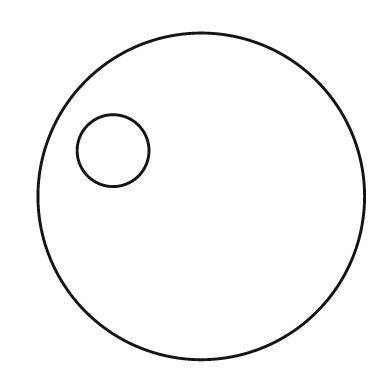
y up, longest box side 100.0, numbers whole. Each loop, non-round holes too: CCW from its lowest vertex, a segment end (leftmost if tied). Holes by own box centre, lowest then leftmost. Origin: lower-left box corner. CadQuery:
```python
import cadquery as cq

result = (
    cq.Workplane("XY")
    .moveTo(50.0, 50.0)
    .circle(50.0)
    .moveTo(23.0, 64.0)
    .circle(11.0)
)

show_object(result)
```